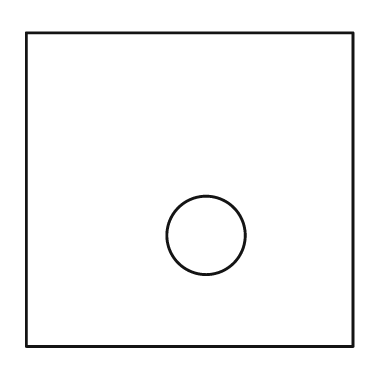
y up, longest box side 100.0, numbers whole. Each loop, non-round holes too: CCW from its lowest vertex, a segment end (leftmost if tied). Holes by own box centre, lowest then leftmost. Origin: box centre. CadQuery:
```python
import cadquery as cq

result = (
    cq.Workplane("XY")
    .moveTo(-50.0, -48.0)
    .lineTo(50.0, -48.0)
    .lineTo(50.0, 48.0)
    .lineTo(-50.0, 48.0)
    .close()
    .moveTo(5.0, -14.0)
    .circle(12.0)
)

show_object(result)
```